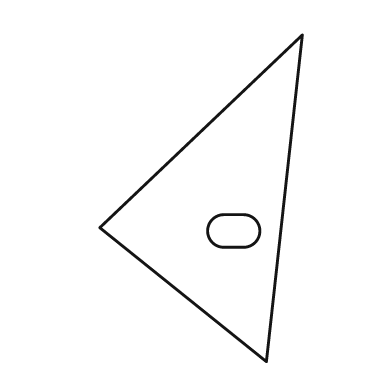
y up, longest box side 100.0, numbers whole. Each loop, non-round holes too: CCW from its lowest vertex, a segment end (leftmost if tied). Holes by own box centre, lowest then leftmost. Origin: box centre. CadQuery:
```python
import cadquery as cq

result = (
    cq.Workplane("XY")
    .moveTo(20.0, -50.0)
    .lineTo(31.0, 50.0)
    .lineTo(-31.0, -9.0)
    .close()
    .moveTo(7.0, -15.0)
    .lineTo(13.0, -15.0)
    .threePointArc((18.0, -10.0), (13.0, -5.0))
    .lineTo(7.0, -5.0)
    .threePointArc((2.0, -10.0), (7.0, -15.0))
    .close()
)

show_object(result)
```